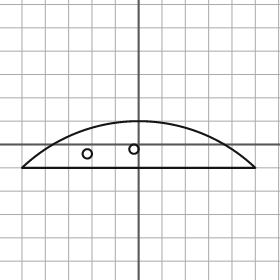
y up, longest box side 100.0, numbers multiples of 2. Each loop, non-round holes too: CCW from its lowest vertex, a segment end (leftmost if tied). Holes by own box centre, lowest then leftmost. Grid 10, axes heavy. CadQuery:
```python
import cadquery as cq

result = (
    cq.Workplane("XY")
    .moveTo(-50.0, -10.0)
    .lineTo(50.0, -10.0)
    .threePointArc((0.0, 10.0), (-50.0, -10.0))
    .close()
    .moveTo(-22.0, -4.0)
    .circle(2.0)
    .moveTo(-2.0, -2.0)
    .circle(2.0)
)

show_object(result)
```